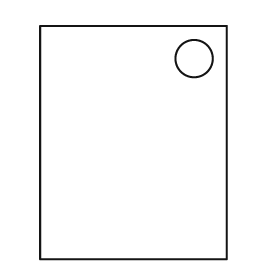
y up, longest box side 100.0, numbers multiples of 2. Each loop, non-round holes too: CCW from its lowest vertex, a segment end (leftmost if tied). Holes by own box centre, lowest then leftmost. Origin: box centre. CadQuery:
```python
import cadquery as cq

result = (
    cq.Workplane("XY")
    .moveTo(-40.0, -50.0)
    .lineTo(40.0, -50.0)
    .lineTo(40.0, 50.0)
    .lineTo(-40.0, 50.0)
    .close()
    .moveTo(26.0, 36.0)
    .circle(8.0)
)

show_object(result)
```